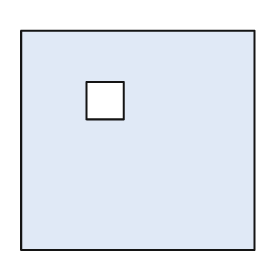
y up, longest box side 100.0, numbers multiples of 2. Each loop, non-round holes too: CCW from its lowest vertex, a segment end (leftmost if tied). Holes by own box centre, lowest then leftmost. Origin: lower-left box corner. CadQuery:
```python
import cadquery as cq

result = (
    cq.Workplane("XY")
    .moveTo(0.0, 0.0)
    .lineTo(100.0, 0.0)
    .lineTo(100.0, 94.0)
    .lineTo(0.0, 94.0)
    .close()
    .moveTo(28.0, 56.0)
    .lineTo(44.0, 56.0)
    .lineTo(44.0, 72.0)
    .lineTo(28.0, 72.0)
    .close()
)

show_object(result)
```